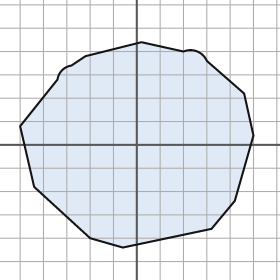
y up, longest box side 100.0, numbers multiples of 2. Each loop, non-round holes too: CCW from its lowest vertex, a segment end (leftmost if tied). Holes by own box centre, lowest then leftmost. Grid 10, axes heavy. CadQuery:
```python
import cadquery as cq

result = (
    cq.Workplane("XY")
    .moveTo(-6.0, -44.0)
    .lineTo(32.0, -36.0)
    .lineTo(42.0, -24.0)
    .lineTo(50.0, 4.0)
    .lineTo(46.0, 22.0)
    .lineTo(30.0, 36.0)
    .threePointArc((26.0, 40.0), (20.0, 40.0))
    .lineTo(2.0, 44.0)
    .lineTo(-22.0, 38.0)
    .lineTo(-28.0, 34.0)
    .threePointArc((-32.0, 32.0), (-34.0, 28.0))
    .lineTo(-50.0, 8.0)
    .lineTo(-44.0, -18.0)
    .lineTo(-20.0, -40.0)
    .close()
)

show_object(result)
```